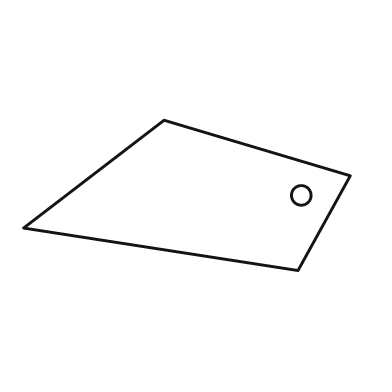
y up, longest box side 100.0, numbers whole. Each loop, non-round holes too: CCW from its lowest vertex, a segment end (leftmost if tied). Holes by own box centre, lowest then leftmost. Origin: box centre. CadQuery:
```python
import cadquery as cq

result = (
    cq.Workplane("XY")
    .moveTo(34.0, -23.0)
    .lineTo(50.0, 6.0)
    .lineTo(-7.0, 23.0)
    .lineTo(-50.0, -10.0)
    .close()
    .moveTo(35.0, 0.0)
    .circle(3.0)
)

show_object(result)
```